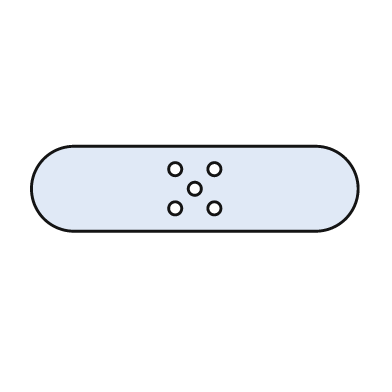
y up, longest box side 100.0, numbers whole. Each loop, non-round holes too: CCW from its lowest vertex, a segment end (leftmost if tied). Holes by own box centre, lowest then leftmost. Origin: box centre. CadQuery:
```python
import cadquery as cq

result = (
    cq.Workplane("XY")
    .moveTo(-37.0, -13.0)
    .lineTo(37.0, -13.0)
    .threePointArc((50.0, 0.0), (37.0, 13.0))
    .lineTo(-37.0, 13.0)
    .threePointArc((-50.0, 0.0), (-37.0, -13.0))
    .close()
    .moveTo(-6.0, -6.0)
    .circle(2.0)
    .moveTo(6.0, -6.0)
    .circle(2.0)
    .moveTo(0.0, 0.0)
    .circle(2.0)
    .moveTo(-6.0, 6.0)
    .circle(2.0)
    .moveTo(6.0, 6.0)
    .circle(2.0)
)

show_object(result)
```